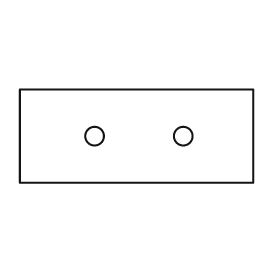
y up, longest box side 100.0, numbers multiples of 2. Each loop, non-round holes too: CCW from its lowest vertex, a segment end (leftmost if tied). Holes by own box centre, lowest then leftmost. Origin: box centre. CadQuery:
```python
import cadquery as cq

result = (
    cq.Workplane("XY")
    .moveTo(-50.0, -20.0)
    .lineTo(50.0, -20.0)
    .lineTo(50.0, 20.0)
    .lineTo(-50.0, 20.0)
    .close()
    .moveTo(-18.0, 0.0)
    .circle(4.0)
    .moveTo(20.0, 0.0)
    .circle(4.0)
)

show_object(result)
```